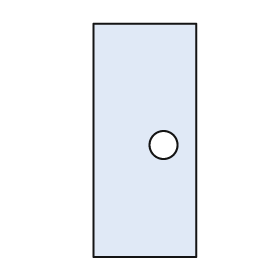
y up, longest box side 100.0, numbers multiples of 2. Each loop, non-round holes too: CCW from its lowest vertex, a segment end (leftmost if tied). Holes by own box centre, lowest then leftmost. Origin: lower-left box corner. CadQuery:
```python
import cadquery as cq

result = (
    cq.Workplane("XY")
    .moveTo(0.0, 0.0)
    .lineTo(44.0, 0.0)
    .lineTo(44.0, 100.0)
    .lineTo(0.0, 100.0)
    .close()
    .moveTo(30.0, 48.0)
    .circle(6.0)
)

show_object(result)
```